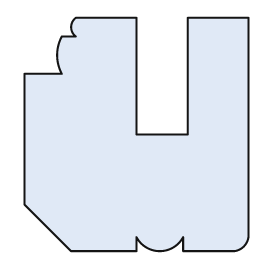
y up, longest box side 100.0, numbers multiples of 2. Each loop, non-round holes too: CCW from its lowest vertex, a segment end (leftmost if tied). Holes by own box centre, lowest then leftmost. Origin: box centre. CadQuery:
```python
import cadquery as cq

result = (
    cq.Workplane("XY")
    .moveTo(-28.0, -50.0)
    .lineTo(0.0, -50.0)
    .lineTo(0.0, -44.0)
    .threePointArc((10.0, -50.0), (20.0, -44.0))
    .lineTo(20.0, -50.0)
    .lineTo(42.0, -50.0)
    .threePointArc((46.0, -48.0), (48.0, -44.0))
    .lineTo(48.0, 50.0)
    .lineTo(22.0, 50.0)
    .lineTo(22.0, 0.0)
    .lineTo(0.0, 0.0)
    .lineTo(0.0, 50.0)
    .lineTo(-26.0, 50.0)
    .threePointArc((-28.0, 46.0), (-26.0, 42.0))
    .lineTo(-32.0, 42.0)
    .threePointArc((-34.0, 34.0), (-32.0, 26.0))
    .lineTo(-48.0, 26.0)
    .lineTo(-48.0, -30.0)
    .close()
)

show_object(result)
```